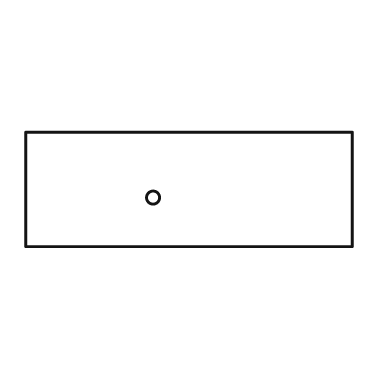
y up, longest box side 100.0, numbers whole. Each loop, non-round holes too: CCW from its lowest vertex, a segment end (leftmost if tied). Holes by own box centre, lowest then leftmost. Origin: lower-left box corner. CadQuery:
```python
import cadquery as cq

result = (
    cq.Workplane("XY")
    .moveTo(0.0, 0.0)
    .lineTo(100.0, 0.0)
    .lineTo(100.0, 35.0)
    .lineTo(0.0, 35.0)
    .close()
    .moveTo(39.0, 15.0)
    .circle(2.0)
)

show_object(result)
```